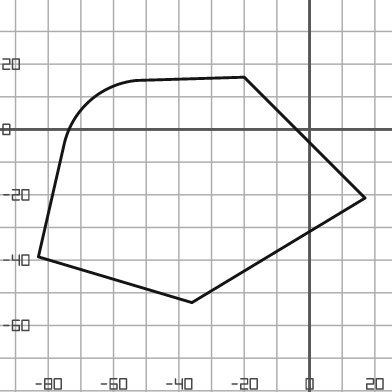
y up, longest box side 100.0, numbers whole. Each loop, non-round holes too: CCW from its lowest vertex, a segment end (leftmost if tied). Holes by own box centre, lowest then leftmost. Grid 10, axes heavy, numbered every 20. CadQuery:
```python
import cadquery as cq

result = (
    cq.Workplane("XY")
    .moveTo(-36.0, -53.0)
    .lineTo(17.0, -21.0)
    .lineTo(-20.0, 16.0)
    .lineTo(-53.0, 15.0)
    .threePointArc((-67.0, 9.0), (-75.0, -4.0))
    .lineTo(-83.0, -39.0)
    .close()
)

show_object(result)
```